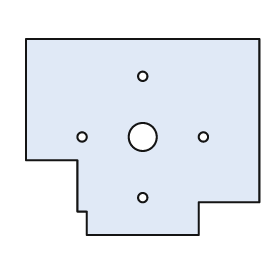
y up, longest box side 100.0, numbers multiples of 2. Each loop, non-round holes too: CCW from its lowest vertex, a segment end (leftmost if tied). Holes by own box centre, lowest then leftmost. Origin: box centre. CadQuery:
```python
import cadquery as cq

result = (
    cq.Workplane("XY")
    .moveTo(-24.0, -42.0)
    .lineTo(24.0, -42.0)
    .lineTo(24.0, -28.0)
    .lineTo(50.0, -28.0)
    .lineTo(50.0, 42.0)
    .lineTo(-50.0, 42.0)
    .lineTo(-50.0, -10.0)
    .lineTo(-28.0, -10.0)
    .lineTo(-28.0, -32.0)
    .lineTo(-24.0, -32.0)
    .close()
    .moveTo(0.0, -26.0)
    .circle(2.0)
    .moveTo(-26.0, 0.0)
    .circle(2.0)
    .moveTo(0.0, 0.0)
    .circle(6.0)
    .moveTo(26.0, 0.0)
    .circle(2.0)
    .moveTo(0.0, 26.0)
    .circle(2.0)
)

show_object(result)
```